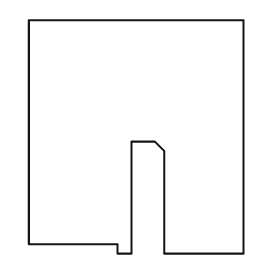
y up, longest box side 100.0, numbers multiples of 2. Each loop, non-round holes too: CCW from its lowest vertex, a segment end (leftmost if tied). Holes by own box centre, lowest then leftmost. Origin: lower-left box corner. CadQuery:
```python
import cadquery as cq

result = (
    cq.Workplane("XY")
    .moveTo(38.0, 0.0)
    .lineTo(44.0, 0.0)
    .lineTo(44.0, 48.0)
    .lineTo(54.0, 48.0)
    .lineTo(58.0, 44.0)
    .lineTo(58.0, 0.0)
    .lineTo(92.0, 0.0)
    .lineTo(92.0, 100.0)
    .lineTo(0.0, 100.0)
    .lineTo(0.0, 4.0)
    .lineTo(38.0, 4.0)
    .close()
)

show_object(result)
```